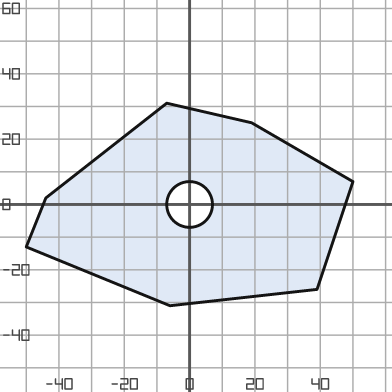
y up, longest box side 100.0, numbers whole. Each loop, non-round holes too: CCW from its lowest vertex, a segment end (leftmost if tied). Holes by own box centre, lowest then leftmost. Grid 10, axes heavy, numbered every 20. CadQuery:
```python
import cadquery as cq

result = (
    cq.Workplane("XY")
    .moveTo(-6.0, -31.0)
    .lineTo(39.0, -26.0)
    .lineTo(50.0, 7.0)
    .lineTo(19.0, 25.0)
    .lineTo(-7.0, 31.0)
    .lineTo(-44.0, 2.0)
    .lineTo(-50.0, -13.0)
    .close()
    .moveTo(0.0, 0.0)
    .circle(7.0)
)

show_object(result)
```